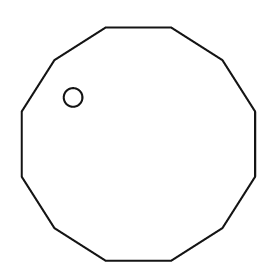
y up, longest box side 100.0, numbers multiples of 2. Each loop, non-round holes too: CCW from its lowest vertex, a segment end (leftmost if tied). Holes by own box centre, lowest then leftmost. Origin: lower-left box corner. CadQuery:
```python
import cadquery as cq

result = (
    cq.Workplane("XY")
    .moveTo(36.0, 0.0)
    .lineTo(64.0, 0.0)
    .lineTo(86.0, 14.0)
    .lineTo(100.0, 36.0)
    .lineTo(100.0, 64.0)
    .lineTo(86.0, 86.0)
    .lineTo(64.0, 100.0)
    .lineTo(36.0, 100.0)
    .lineTo(14.0, 86.0)
    .lineTo(0.0, 64.0)
    .lineTo(0.0, 36.0)
    .lineTo(14.0, 14.0)
    .close()
    .moveTo(22.0, 70.0)
    .circle(4.0)
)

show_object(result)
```